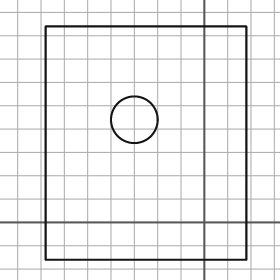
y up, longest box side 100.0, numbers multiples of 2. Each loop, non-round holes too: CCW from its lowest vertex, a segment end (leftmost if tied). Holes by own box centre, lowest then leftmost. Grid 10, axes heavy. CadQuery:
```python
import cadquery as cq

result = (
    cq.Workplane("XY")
    .moveTo(-68.0, -16.0)
    .lineTo(18.0, -16.0)
    .lineTo(18.0, 84.0)
    .lineTo(-68.0, 84.0)
    .close()
    .moveTo(-30.0, 44.0)
    .circle(10.0)
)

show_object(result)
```